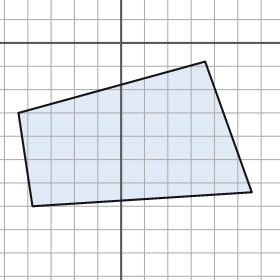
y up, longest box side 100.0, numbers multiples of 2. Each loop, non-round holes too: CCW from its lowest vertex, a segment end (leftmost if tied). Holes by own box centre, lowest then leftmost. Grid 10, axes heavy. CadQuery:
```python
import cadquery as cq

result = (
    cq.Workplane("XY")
    .moveTo(-38.0, -70.0)
    .lineTo(56.0, -64.0)
    .lineTo(36.0, -8.0)
    .lineTo(-44.0, -30.0)
    .close()
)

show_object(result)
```